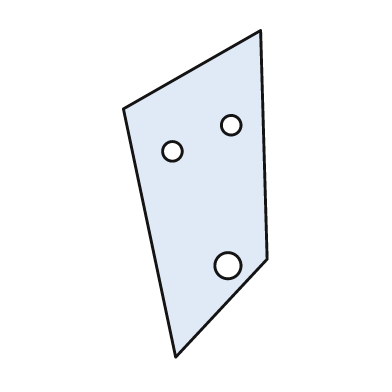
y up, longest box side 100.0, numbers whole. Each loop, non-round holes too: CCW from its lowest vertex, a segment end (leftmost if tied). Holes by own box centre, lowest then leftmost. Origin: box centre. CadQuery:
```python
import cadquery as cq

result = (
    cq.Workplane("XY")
    .moveTo(-6.0, -50.0)
    .lineTo(22.0, -20.0)
    .lineTo(20.0, 50.0)
    .lineTo(-22.0, 26.0)
    .close()
    .moveTo(10.0, -22.0)
    .circle(4.0)
    .moveTo(-7.0, 13.0)
    .circle(3.0)
    .moveTo(11.0, 21.0)
    .circle(3.0)
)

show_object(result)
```